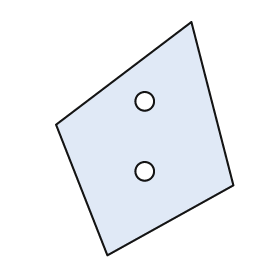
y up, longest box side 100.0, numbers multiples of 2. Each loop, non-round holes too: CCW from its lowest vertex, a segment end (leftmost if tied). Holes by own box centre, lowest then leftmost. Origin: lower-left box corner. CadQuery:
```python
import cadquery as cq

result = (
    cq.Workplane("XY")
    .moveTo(22.0, 0.0)
    .lineTo(76.0, 30.0)
    .lineTo(58.0, 100.0)
    .lineTo(0.0, 56.0)
    .close()
    .moveTo(38.0, 36.0)
    .circle(4.0)
    .moveTo(38.0, 66.0)
    .circle(4.0)
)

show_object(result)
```